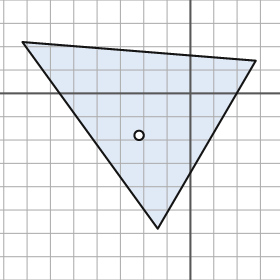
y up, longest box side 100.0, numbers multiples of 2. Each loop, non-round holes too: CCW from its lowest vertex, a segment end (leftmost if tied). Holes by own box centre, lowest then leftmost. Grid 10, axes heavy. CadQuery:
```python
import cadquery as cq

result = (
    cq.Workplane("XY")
    .moveTo(-14.0, -58.0)
    .lineTo(28.0, 14.0)
    .lineTo(-72.0, 22.0)
    .close()
    .moveTo(-22.0, -18.0)
    .circle(2.0)
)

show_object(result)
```